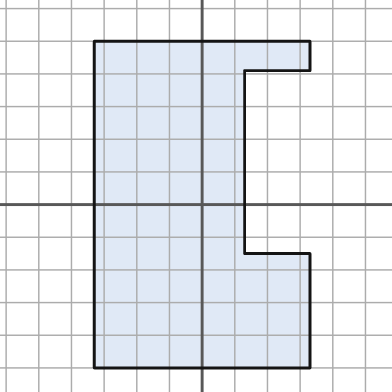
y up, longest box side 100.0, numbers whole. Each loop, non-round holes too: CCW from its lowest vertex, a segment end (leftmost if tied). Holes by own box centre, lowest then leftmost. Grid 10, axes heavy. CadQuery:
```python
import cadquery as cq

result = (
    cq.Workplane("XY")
    .moveTo(-33.0, -50.0)
    .lineTo(33.0, -50.0)
    .lineTo(33.0, -15.0)
    .lineTo(13.0, -15.0)
    .lineTo(13.0, 41.0)
    .lineTo(33.0, 41.0)
    .lineTo(33.0, 50.0)
    .lineTo(-33.0, 50.0)
    .close()
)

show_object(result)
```